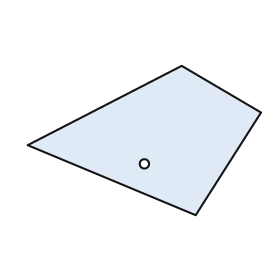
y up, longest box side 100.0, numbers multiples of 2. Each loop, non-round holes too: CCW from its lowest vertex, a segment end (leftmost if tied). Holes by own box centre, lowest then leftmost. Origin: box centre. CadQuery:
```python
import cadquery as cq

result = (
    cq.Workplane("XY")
    .moveTo(22.0, -32.0)
    .lineTo(50.0, 12.0)
    .lineTo(16.0, 32.0)
    .lineTo(-50.0, -2.0)
    .close()
    .moveTo(0.0, -10.0)
    .circle(2.0)
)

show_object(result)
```